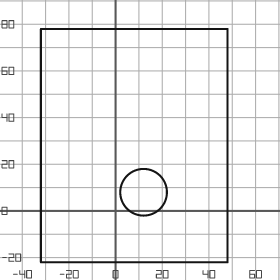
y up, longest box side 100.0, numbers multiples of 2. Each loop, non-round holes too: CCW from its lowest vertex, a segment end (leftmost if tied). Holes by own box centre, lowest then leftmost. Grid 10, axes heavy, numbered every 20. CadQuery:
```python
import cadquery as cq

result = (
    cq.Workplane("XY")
    .moveTo(-32.0, -22.0)
    .lineTo(48.0, -22.0)
    .lineTo(48.0, 78.0)
    .lineTo(-32.0, 78.0)
    .close()
    .moveTo(12.0, 8.0)
    .circle(10.0)
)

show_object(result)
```